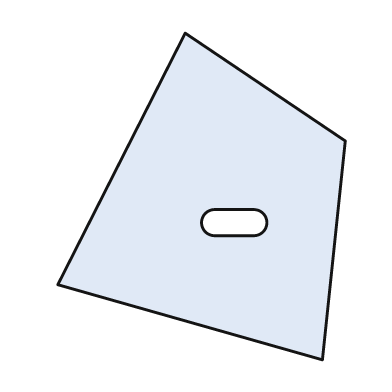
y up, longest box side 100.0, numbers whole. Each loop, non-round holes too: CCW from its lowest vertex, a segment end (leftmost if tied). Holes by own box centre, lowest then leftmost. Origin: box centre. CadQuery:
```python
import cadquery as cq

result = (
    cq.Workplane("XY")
    .moveTo(37.0, -50.0)
    .lineTo(44.0, 17.0)
    .lineTo(-5.0, 50.0)
    .lineTo(-44.0, -27.0)
    .close()
    .moveTo(4.0, -12.0)
    .lineTo(16.0, -12.0)
    .threePointArc((20.0, -8.0), (16.0, -4.0))
    .lineTo(4.0, -4.0)
    .threePointArc((0.0, -8.0), (4.0, -12.0))
    .close()
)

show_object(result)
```